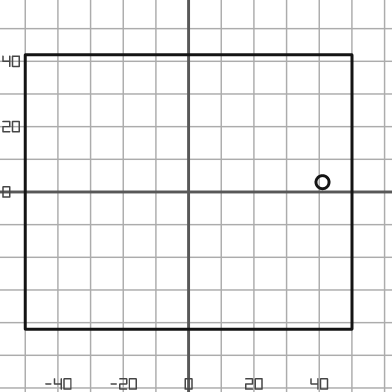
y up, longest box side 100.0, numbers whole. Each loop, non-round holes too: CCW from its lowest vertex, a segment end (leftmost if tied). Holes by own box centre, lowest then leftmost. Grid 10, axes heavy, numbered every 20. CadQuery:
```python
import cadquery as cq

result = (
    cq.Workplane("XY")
    .moveTo(-50.0, -42.0)
    .lineTo(50.0, -42.0)
    .lineTo(50.0, 42.0)
    .lineTo(-50.0, 42.0)
    .close()
    .moveTo(41.0, 3.0)
    .circle(2.0)
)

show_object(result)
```